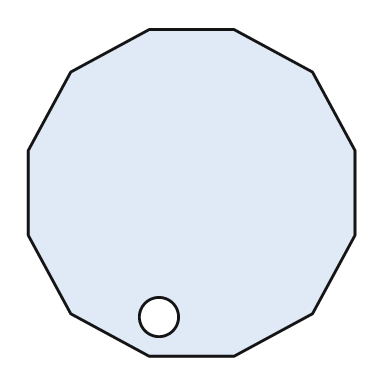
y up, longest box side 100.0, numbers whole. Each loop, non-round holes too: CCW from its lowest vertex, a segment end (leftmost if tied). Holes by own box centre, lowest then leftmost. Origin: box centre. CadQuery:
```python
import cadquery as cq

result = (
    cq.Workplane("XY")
    .moveTo(-13.0, -50.0)
    .lineTo(13.0, -50.0)
    .lineTo(37.0, -37.0)
    .lineTo(50.0, -13.0)
    .lineTo(50.0, 13.0)
    .lineTo(37.0, 37.0)
    .lineTo(13.0, 50.0)
    .lineTo(-13.0, 50.0)
    .lineTo(-37.0, 37.0)
    .lineTo(-50.0, 13.0)
    .lineTo(-50.0, -13.0)
    .lineTo(-37.0, -37.0)
    .close()
    .moveTo(-10.0, -38.0)
    .circle(6.0)
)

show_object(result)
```